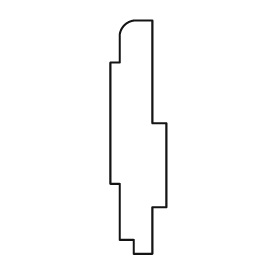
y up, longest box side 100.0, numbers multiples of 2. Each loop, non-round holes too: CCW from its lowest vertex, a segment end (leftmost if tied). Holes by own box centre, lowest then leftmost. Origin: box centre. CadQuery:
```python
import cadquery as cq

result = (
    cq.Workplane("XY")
    .moveTo(-2.0, -50.0)
    .lineTo(6.0, -50.0)
    .lineTo(6.0, -30.0)
    .lineTo(12.0, -30.0)
    .lineTo(12.0, 6.0)
    .lineTo(6.0, 6.0)
    .lineTo(6.0, 50.0)
    .lineTo(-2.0, 50.0)
    .threePointArc((-6.0, 48.0), (-8.0, 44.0))
    .lineTo(-8.0, 32.0)
    .lineTo(-12.0, 32.0)
    .lineTo(-12.0, -20.0)
    .lineTo(-8.0, -20.0)
    .lineTo(-8.0, -44.0)
    .lineTo(-2.0, -44.0)
    .close()
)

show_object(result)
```